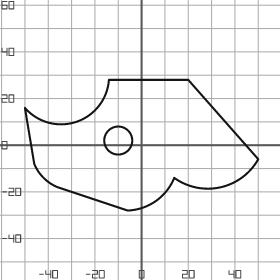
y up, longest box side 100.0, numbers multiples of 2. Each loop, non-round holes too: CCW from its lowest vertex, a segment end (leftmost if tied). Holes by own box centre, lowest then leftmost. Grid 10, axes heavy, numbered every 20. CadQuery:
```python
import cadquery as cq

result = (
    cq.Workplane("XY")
    .moveTo(-6.0, -28.0)
    .threePointArc((6.0, -24.0), (14.0, -14.0))
    .threePointArc((34.0, -18.0), (50.0, -6.0))
    .lineTo(20.0, 28.0)
    .lineTo(-14.0, 28.0)
    .threePointArc((-28.0, 10.0), (-50.0, 16.0))
    .lineTo(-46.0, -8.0)
    .threePointArc((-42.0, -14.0), (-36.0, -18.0))
    .close()
    .moveTo(-10.0, 2.0)
    .circle(6.0)
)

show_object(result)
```